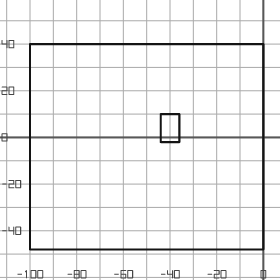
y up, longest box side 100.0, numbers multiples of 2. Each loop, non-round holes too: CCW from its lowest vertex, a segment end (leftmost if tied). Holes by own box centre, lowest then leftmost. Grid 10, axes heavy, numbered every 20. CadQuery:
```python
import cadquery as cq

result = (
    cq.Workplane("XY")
    .moveTo(-100.0, -48.0)
    .lineTo(0.0, -48.0)
    .lineTo(0.0, 40.0)
    .lineTo(-100.0, 40.0)
    .close()
    .moveTo(-44.0, -2.0)
    .lineTo(-36.0, -2.0)
    .lineTo(-36.0, 10.0)
    .lineTo(-44.0, 10.0)
    .close()
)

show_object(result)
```